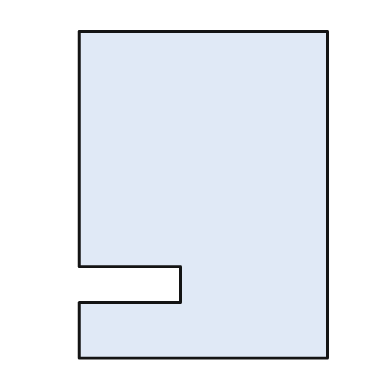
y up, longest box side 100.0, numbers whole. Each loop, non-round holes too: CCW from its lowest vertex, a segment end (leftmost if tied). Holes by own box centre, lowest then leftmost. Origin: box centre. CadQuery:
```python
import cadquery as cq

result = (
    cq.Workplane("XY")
    .moveTo(-38.0, -50.0)
    .lineTo(38.0, -50.0)
    .lineTo(38.0, 50.0)
    .lineTo(-38.0, 50.0)
    .lineTo(-38.0, -22.0)
    .lineTo(-7.0, -22.0)
    .lineTo(-7.0, -33.0)
    .lineTo(-38.0, -33.0)
    .close()
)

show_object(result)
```